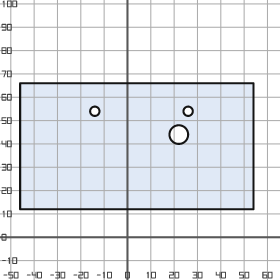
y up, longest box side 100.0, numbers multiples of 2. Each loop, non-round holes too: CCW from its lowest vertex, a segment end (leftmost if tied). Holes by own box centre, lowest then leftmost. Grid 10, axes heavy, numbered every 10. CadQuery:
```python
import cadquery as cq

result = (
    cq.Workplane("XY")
    .moveTo(-46.0, 12.0)
    .lineTo(54.0, 12.0)
    .lineTo(54.0, 66.0)
    .lineTo(-46.0, 66.0)
    .close()
    .moveTo(22.0, 44.0)
    .circle(4.0)
    .moveTo(-14.0, 54.0)
    .circle(2.0)
    .moveTo(26.0, 54.0)
    .circle(2.0)
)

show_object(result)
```